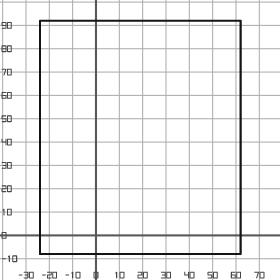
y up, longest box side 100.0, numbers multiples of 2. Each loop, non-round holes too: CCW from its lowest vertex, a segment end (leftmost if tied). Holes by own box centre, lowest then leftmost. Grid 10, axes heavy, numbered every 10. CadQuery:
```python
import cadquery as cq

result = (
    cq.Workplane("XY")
    .moveTo(-24.0, -8.0)
    .lineTo(62.0, -8.0)
    .lineTo(62.0, 92.0)
    .lineTo(-24.0, 92.0)
    .close()
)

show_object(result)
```